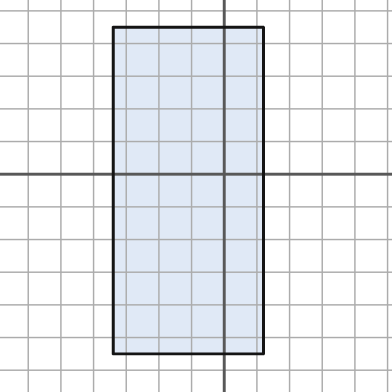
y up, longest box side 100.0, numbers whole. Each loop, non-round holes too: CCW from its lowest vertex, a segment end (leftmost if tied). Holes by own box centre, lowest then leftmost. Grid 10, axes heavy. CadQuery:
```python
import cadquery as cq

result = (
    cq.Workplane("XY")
    .moveTo(-34.0, -55.0)
    .lineTo(12.0, -55.0)
    .lineTo(12.0, 45.0)
    .lineTo(-34.0, 45.0)
    .close()
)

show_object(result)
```